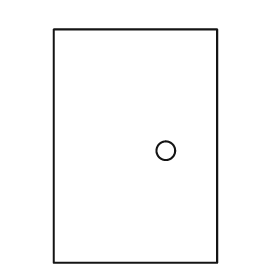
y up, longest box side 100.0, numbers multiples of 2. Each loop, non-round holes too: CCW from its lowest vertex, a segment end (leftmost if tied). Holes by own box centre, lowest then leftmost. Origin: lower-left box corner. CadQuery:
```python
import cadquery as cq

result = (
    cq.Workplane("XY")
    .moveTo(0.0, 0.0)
    .lineTo(70.0, 0.0)
    .lineTo(70.0, 100.0)
    .lineTo(0.0, 100.0)
    .close()
    .moveTo(48.0, 48.0)
    .circle(4.0)
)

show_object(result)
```